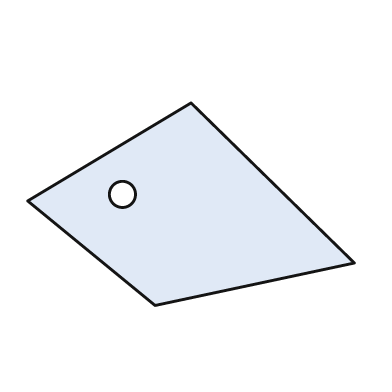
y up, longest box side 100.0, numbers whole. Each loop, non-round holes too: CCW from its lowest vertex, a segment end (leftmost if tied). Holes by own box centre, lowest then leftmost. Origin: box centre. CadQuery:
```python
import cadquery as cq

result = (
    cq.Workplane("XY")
    .moveTo(-11.0, -31.0)
    .lineTo(50.0, -18.0)
    .lineTo(0.0, 31.0)
    .lineTo(-50.0, 1.0)
    .close()
    .moveTo(-21.0, 3.0)
    .circle(4.0)
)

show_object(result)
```